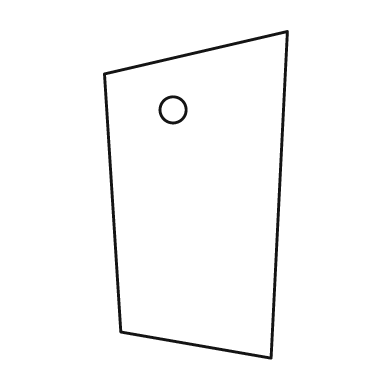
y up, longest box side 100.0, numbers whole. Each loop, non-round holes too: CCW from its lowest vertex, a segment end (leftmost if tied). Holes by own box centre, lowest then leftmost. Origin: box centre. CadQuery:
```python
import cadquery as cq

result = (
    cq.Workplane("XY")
    .moveTo(23.0, -50.0)
    .lineTo(28.0, 50.0)
    .lineTo(-28.0, 37.0)
    .lineTo(-23.0, -42.0)
    .close()
    .moveTo(-7.0, 26.0)
    .circle(4.0)
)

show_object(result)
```